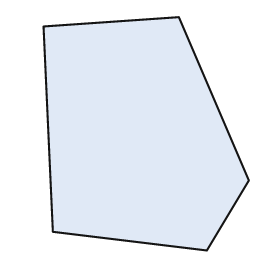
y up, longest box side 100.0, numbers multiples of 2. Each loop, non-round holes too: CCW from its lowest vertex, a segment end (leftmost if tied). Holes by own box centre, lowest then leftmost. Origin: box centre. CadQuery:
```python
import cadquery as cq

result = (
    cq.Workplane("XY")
    .moveTo(26.0, -50.0)
    .lineTo(44.0, -20.0)
    .lineTo(14.0, 50.0)
    .lineTo(-44.0, 46.0)
    .lineTo(-40.0, -42.0)
    .close()
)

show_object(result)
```